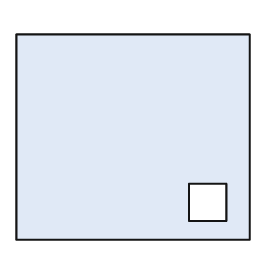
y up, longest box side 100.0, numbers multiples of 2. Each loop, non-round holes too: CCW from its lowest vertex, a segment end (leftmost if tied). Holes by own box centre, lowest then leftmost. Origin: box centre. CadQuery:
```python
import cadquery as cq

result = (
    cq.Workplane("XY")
    .moveTo(-50.0, -44.0)
    .lineTo(50.0, -44.0)
    .lineTo(50.0, 44.0)
    .lineTo(-50.0, 44.0)
    .close()
    .moveTo(24.0, -36.0)
    .lineTo(40.0, -36.0)
    .lineTo(40.0, -20.0)
    .lineTo(24.0, -20.0)
    .close()
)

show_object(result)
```